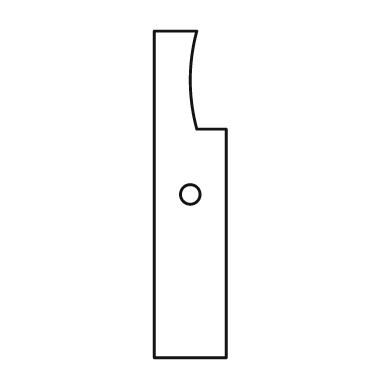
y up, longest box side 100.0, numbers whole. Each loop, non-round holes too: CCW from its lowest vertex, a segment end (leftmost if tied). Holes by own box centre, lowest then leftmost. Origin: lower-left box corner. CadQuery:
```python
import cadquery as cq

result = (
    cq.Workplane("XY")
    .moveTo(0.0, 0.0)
    .lineTo(22.0, 0.0)
    .lineTo(22.0, 70.0)
    .lineTo(13.0, 70.0)
    .threePointArc((11.0, 85.0), (13.0, 100.0))
    .lineTo(0.0, 100.0)
    .close()
    .moveTo(11.0, 50.0)
    .circle(3.0)
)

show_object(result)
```